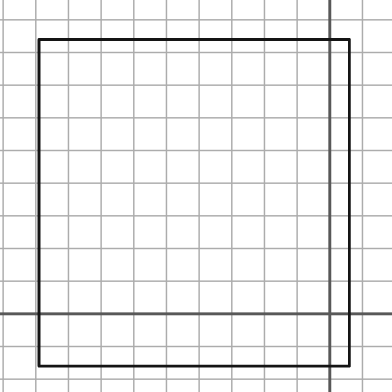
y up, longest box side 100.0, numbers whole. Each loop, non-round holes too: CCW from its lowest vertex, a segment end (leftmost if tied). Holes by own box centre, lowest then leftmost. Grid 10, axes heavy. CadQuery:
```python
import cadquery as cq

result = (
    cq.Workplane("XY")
    .moveTo(-89.0, -16.0)
    .lineTo(6.0, -16.0)
    .lineTo(6.0, 84.0)
    .lineTo(-89.0, 84.0)
    .close()
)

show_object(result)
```